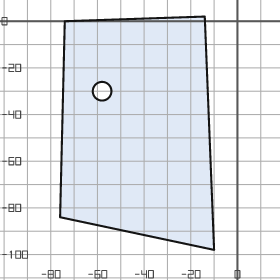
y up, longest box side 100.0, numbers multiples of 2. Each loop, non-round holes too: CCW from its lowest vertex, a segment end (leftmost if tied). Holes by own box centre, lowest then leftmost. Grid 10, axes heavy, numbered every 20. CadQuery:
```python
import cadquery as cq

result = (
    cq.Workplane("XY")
    .moveTo(-10.0, -98.0)
    .lineTo(-14.0, 2.0)
    .lineTo(-74.0, 0.0)
    .lineTo(-76.0, -84.0)
    .close()
    .moveTo(-58.0, -30.0)
    .circle(4.0)
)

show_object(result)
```